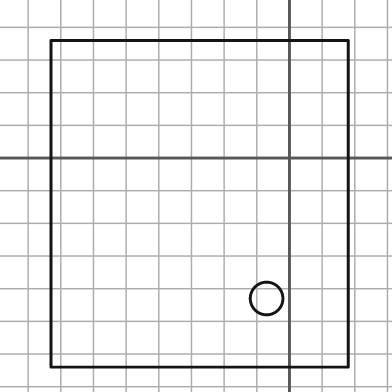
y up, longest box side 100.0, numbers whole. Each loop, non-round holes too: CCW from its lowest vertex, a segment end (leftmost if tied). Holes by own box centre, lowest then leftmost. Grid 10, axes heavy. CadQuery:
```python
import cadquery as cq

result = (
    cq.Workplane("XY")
    .moveTo(-73.0, -64.0)
    .lineTo(18.0, -64.0)
    .lineTo(18.0, 36.0)
    .lineTo(-73.0, 36.0)
    .close()
    .moveTo(-7.0, -43.0)
    .circle(5.0)
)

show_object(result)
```